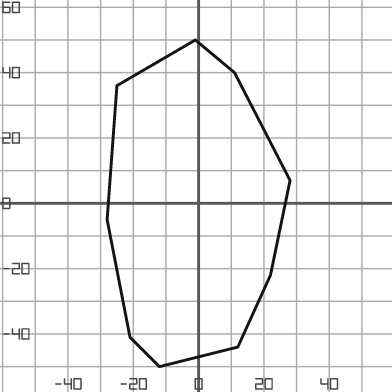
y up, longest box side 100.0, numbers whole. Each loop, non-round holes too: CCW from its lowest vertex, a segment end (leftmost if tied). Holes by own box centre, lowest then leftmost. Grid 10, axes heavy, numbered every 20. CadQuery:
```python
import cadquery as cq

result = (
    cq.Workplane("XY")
    .moveTo(-12.0, -50.0)
    .lineTo(12.0, -44.0)
    .lineTo(22.0, -22.0)
    .lineTo(28.0, 7.0)
    .lineTo(11.0, 40.0)
    .lineTo(-1.0, 50.0)
    .lineTo(-25.0, 36.0)
    .lineTo(-28.0, -5.0)
    .lineTo(-21.0, -41.0)
    .close()
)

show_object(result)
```